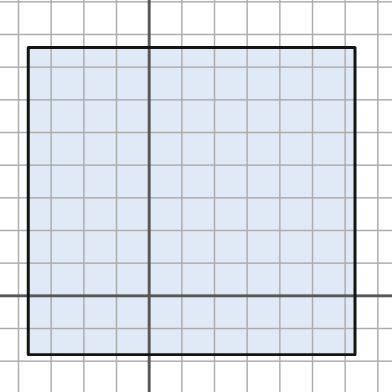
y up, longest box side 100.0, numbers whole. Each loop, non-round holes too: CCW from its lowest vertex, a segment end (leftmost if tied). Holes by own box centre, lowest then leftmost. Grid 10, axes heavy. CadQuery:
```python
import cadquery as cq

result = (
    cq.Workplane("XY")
    .moveTo(-37.0, -18.0)
    .lineTo(63.0, -18.0)
    .lineTo(63.0, 76.0)
    .lineTo(-37.0, 76.0)
    .close()
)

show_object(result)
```